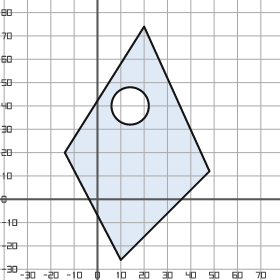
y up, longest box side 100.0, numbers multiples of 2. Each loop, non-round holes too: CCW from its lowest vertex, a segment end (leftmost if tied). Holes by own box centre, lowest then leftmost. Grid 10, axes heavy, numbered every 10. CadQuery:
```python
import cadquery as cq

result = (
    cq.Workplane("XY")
    .moveTo(10.0, -26.0)
    .lineTo(48.0, 12.0)
    .lineTo(20.0, 74.0)
    .lineTo(-14.0, 20.0)
    .close()
    .moveTo(14.0, 40.0)
    .circle(8.0)
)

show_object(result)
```